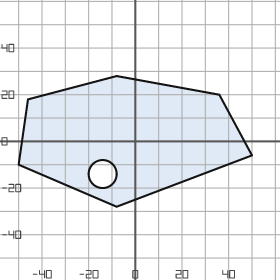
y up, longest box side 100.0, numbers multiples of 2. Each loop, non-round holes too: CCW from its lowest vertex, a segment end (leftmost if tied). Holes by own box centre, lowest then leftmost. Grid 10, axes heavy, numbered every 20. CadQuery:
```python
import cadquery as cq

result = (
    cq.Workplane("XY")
    .moveTo(-8.0, -28.0)
    .lineTo(50.0, -6.0)
    .lineTo(36.0, 20.0)
    .lineTo(-8.0, 28.0)
    .lineTo(-46.0, 18.0)
    .lineTo(-50.0, -10.0)
    .close()
    .moveTo(-14.0, -14.0)
    .circle(6.0)
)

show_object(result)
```